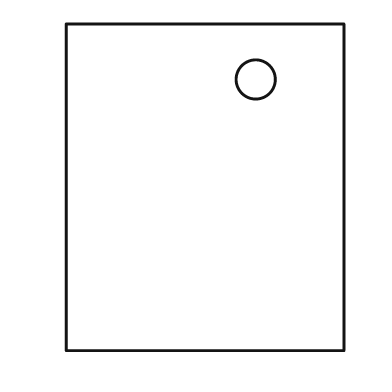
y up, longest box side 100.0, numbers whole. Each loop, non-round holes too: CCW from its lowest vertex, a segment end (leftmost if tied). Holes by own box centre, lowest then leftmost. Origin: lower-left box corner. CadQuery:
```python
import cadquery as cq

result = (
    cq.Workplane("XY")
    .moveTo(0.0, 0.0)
    .lineTo(85.0, 0.0)
    .lineTo(85.0, 100.0)
    .lineTo(0.0, 100.0)
    .close()
    .moveTo(58.0, 83.0)
    .circle(6.0)
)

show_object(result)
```